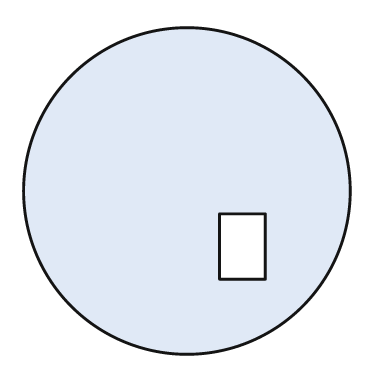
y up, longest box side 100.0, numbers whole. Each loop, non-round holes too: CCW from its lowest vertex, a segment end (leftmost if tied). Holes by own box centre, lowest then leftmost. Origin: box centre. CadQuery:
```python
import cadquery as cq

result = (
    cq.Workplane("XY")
    .moveTo(0.0, 0.0)
    .circle(50.0)
    .moveTo(10.0, -27.0)
    .lineTo(24.0, -27.0)
    .lineTo(24.0, -7.0)
    .lineTo(10.0, -7.0)
    .close()
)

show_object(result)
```